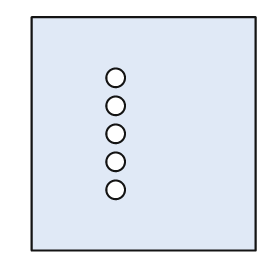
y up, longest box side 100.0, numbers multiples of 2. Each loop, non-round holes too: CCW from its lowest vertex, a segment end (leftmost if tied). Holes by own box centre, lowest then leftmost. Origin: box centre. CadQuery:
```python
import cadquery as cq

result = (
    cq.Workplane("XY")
    .moveTo(-48.0, -50.0)
    .lineTo(48.0, -50.0)
    .lineTo(48.0, 50.0)
    .lineTo(-48.0, 50.0)
    .close()
    .moveTo(-12.0, -24.0)
    .circle(4.0)
    .moveTo(-12.0, -12.0)
    .circle(4.0)
    .moveTo(-12.0, 0.0)
    .circle(4.0)
    .moveTo(-12.0, 12.0)
    .circle(4.0)
    .moveTo(-12.0, 24.0)
    .circle(4.0)
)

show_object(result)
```